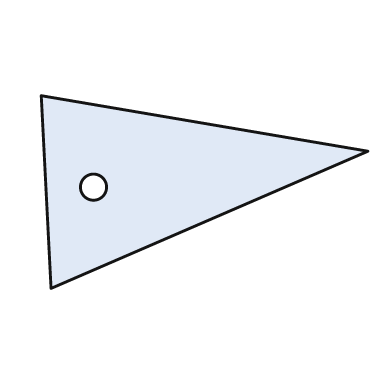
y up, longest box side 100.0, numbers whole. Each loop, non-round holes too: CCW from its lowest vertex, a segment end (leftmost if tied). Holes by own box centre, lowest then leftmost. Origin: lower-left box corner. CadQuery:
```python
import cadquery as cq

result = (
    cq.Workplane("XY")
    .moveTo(3.0, 0.0)
    .lineTo(100.0, 42.0)
    .lineTo(0.0, 59.0)
    .close()
    .moveTo(16.0, 31.0)
    .circle(4.0)
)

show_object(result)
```